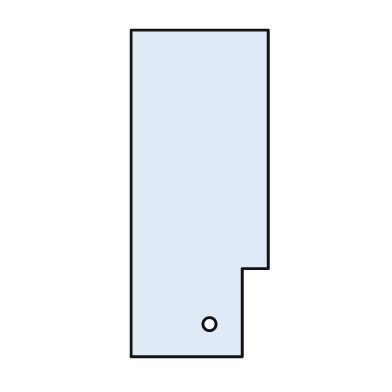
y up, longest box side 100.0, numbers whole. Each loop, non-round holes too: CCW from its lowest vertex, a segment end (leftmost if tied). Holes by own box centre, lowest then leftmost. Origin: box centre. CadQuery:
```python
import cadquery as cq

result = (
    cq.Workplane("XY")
    .moveTo(-21.0, -50.0)
    .lineTo(13.0, -50.0)
    .lineTo(13.0, -23.0)
    .lineTo(21.0, -23.0)
    .lineTo(21.0, 50.0)
    .lineTo(-21.0, 50.0)
    .close()
    .moveTo(3.0, -40.0)
    .circle(2.0)
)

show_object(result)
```